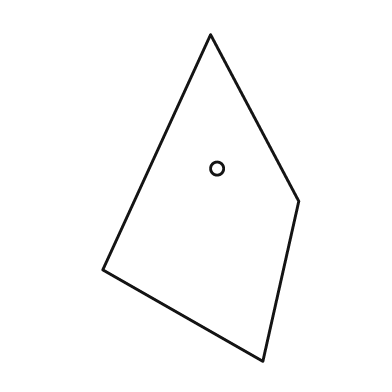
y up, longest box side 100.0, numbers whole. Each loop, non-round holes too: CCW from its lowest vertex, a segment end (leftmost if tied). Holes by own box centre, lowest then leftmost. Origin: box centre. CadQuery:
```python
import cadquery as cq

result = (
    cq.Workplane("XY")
    .moveTo(19.0, -50.0)
    .lineTo(30.0, -1.0)
    .lineTo(3.0, 50.0)
    .lineTo(-30.0, -22.0)
    .close()
    .moveTo(5.0, 9.0)
    .circle(2.0)
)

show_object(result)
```